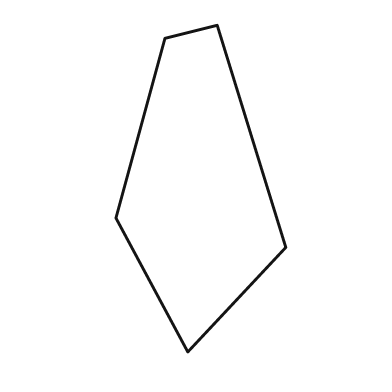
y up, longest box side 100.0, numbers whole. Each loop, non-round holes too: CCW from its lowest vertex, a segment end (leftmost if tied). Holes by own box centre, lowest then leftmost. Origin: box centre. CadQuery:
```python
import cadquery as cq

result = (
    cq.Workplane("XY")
    .moveTo(-4.0, -50.0)
    .lineTo(26.0, -18.0)
    .lineTo(5.0, 50.0)
    .lineTo(-11.0, 46.0)
    .lineTo(-26.0, -9.0)
    .close()
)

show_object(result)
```